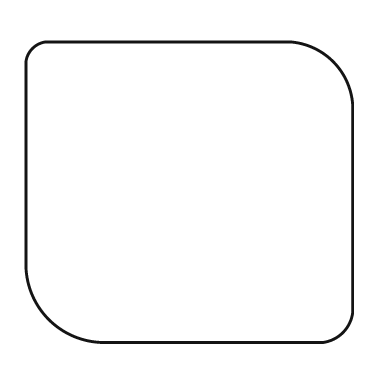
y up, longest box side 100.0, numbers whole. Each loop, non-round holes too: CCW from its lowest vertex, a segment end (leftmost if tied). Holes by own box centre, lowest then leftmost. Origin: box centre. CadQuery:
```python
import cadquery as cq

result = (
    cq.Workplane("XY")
    .moveTo(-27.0, -46.0)
    .lineTo(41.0, -46.0)
    .threePointArc((47.0, -43.0), (50.0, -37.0))
    .lineTo(50.0, 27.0)
    .threePointArc((44.0, 40.0), (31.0, 46.0))
    .lineTo(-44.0, 46.0)
    .threePointArc((-48.0, 44.0), (-50.0, 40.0))
    .lineTo(-50.0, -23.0)
    .threePointArc((-43.0, -39.0), (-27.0, -46.0))
    .close()
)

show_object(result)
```